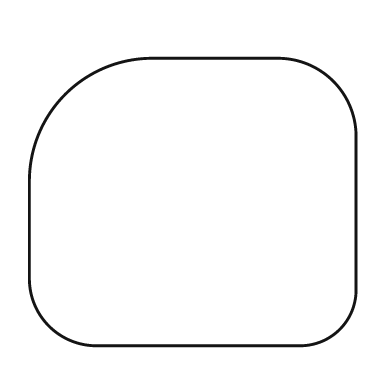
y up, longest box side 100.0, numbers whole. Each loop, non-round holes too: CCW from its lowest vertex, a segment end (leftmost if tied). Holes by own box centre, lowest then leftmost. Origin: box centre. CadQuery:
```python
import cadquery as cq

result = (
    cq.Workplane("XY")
    .moveTo(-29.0, -44.0)
    .lineTo(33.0, -44.0)
    .threePointArc((45.0, -39.0), (50.0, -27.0))
    .lineTo(50.0, 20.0)
    .threePointArc((43.0, 37.0), (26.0, 44.0))
    .lineTo(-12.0, 44.0)
    .threePointArc((-39.0, 33.0), (-50.0, 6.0))
    .lineTo(-50.0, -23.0)
    .threePointArc((-44.0, -38.0), (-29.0, -44.0))
    .close()
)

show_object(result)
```